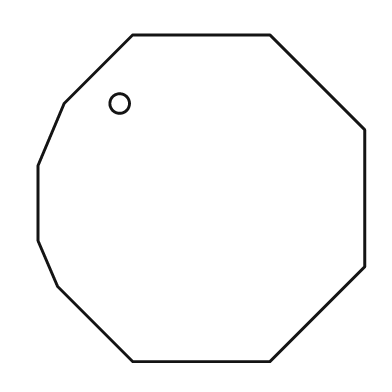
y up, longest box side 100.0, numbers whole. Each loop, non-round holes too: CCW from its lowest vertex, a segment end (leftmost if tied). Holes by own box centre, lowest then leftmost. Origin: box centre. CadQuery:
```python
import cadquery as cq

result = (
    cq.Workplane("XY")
    .moveTo(-21.0, -50.0)
    .lineTo(21.0, -50.0)
    .lineTo(50.0, -21.0)
    .lineTo(50.0, 21.0)
    .lineTo(21.0, 50.0)
    .lineTo(-21.0, 50.0)
    .lineTo(-42.0, 29.0)
    .lineTo(-50.0, 10.0)
    .lineTo(-50.0, -13.0)
    .lineTo(-44.0, -27.0)
    .close()
    .moveTo(-25.0, 29.0)
    .circle(3.0)
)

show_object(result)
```